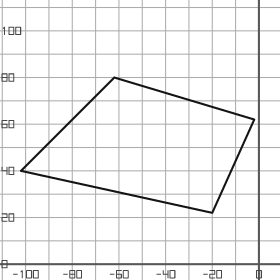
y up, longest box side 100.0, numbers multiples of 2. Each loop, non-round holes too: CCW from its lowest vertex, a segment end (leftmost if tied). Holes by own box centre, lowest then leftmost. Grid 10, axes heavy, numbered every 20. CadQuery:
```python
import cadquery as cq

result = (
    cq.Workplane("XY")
    .moveTo(-20.0, 22.0)
    .lineTo(-2.0, 62.0)
    .lineTo(-62.0, 80.0)
    .lineTo(-102.0, 40.0)
    .close()
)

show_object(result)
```